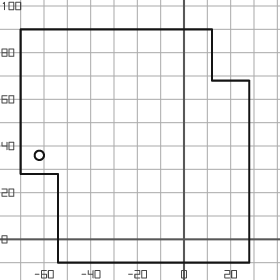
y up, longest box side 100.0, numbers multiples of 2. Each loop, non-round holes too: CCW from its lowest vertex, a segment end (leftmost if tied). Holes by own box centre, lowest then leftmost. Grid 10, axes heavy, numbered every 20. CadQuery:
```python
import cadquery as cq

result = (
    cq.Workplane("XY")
    .moveTo(-54.0, -10.0)
    .lineTo(28.0, -10.0)
    .lineTo(28.0, 68.0)
    .lineTo(12.0, 68.0)
    .lineTo(12.0, 90.0)
    .lineTo(-70.0, 90.0)
    .lineTo(-70.0, 28.0)
    .lineTo(-54.0, 28.0)
    .close()
    .moveTo(-62.0, 36.0)
    .circle(2.0)
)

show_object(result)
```